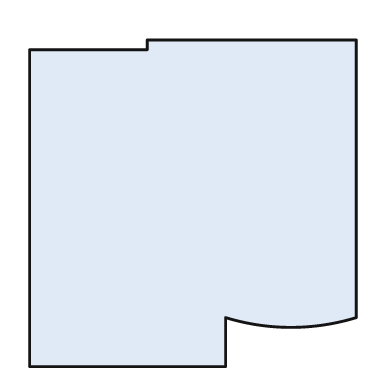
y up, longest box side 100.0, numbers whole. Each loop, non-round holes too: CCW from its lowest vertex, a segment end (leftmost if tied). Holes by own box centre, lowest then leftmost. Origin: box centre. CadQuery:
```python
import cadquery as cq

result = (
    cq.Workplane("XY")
    .moveTo(-50.0, -50.0)
    .lineTo(10.0, -50.0)
    .lineTo(10.0, -35.0)
    .threePointArc((30.0, -38.0), (50.0, -35.0))
    .lineTo(50.0, 50.0)
    .lineTo(-14.0, 50.0)
    .lineTo(-14.0, 47.0)
    .lineTo(-50.0, 47.0)
    .close()
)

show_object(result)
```